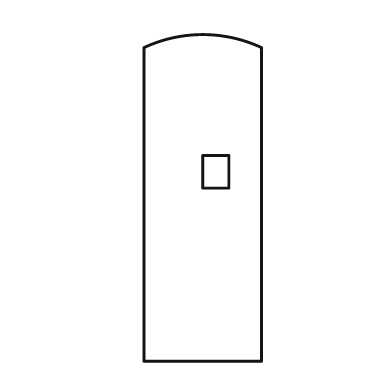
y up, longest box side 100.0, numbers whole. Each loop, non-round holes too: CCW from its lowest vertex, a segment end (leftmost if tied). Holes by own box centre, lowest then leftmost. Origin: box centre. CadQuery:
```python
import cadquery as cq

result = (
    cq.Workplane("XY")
    .moveTo(-18.0, -50.0)
    .lineTo(18.0, -50.0)
    .lineTo(18.0, 46.0)
    .threePointArc((0.0, 50.0), (-18.0, 46.0))
    .close()
    .moveTo(0.0, 3.0)
    .lineTo(8.0, 3.0)
    .lineTo(8.0, 13.0)
    .lineTo(0.0, 13.0)
    .close()
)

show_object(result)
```